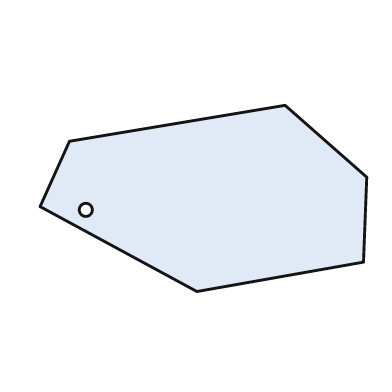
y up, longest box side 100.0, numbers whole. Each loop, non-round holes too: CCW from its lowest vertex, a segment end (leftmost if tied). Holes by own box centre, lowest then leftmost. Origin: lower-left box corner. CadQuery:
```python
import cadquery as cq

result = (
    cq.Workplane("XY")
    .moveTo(48.0, 0.0)
    .lineTo(99.0, 9.0)
    .lineTo(100.0, 35.0)
    .lineTo(75.0, 57.0)
    .lineTo(9.0, 46.0)
    .lineTo(0.0, 26.0)
    .close()
    .moveTo(14.0, 25.0)
    .circle(2.0)
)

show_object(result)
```